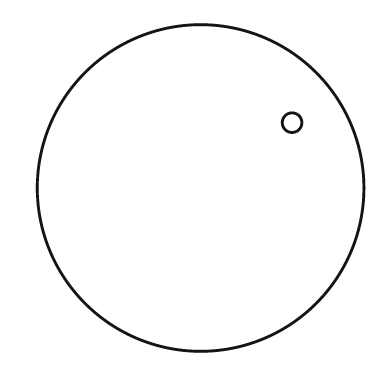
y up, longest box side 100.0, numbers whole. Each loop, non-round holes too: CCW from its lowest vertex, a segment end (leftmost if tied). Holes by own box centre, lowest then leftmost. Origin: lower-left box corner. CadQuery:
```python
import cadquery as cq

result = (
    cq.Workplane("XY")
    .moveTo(50.0, 50.0)
    .circle(50.0)
    .moveTo(78.0, 70.0)
    .circle(3.0)
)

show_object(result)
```